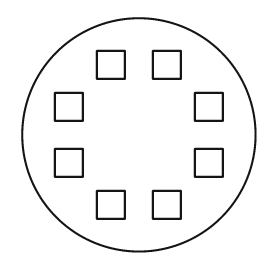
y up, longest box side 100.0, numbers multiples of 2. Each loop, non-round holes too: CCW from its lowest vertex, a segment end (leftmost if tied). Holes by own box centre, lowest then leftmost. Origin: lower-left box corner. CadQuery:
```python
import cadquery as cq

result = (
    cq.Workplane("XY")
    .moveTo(50.0, 50.0)
    .circle(50.0)
    .moveTo(32.0, 14.0)
    .lineTo(44.0, 14.0)
    .lineTo(44.0, 26.0)
    .lineTo(32.0, 26.0)
    .close()
    .moveTo(56.0, 14.0)
    .lineTo(68.0, 14.0)
    .lineTo(68.0, 26.0)
    .lineTo(56.0, 26.0)
    .close()
    .moveTo(14.0, 32.0)
    .lineTo(26.0, 32.0)
    .lineTo(26.0, 44.0)
    .lineTo(14.0, 44.0)
    .close()
    .moveTo(74.0, 32.0)
    .lineTo(86.0, 32.0)
    .lineTo(86.0, 44.0)
    .lineTo(74.0, 44.0)
    .close()
    .moveTo(14.0, 56.0)
    .lineTo(26.0, 56.0)
    .lineTo(26.0, 68.0)
    .lineTo(14.0, 68.0)
    .close()
    .moveTo(74.0, 56.0)
    .lineTo(86.0, 56.0)
    .lineTo(86.0, 68.0)
    .lineTo(74.0, 68.0)
    .close()
    .moveTo(32.0, 74.0)
    .lineTo(44.0, 74.0)
    .lineTo(44.0, 86.0)
    .lineTo(32.0, 86.0)
    .close()
    .moveTo(56.0, 74.0)
    .lineTo(68.0, 74.0)
    .lineTo(68.0, 86.0)
    .lineTo(56.0, 86.0)
    .close()
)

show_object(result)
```